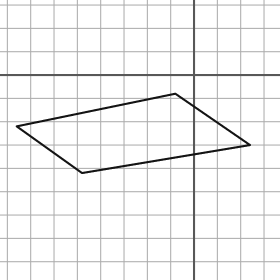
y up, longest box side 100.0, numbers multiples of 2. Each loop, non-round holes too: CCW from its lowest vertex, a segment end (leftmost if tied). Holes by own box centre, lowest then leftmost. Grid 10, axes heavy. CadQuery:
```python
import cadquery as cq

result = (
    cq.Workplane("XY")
    .moveTo(-48.0, -42.0)
    .lineTo(24.0, -30.0)
    .lineTo(-8.0, -8.0)
    .lineTo(-76.0, -22.0)
    .close()
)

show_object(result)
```